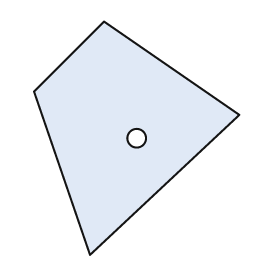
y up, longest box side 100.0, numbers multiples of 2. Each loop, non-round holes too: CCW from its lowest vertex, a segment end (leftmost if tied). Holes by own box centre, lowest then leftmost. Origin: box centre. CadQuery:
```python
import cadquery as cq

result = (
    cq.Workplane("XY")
    .moveTo(-20.0, -50.0)
    .lineTo(44.0, 10.0)
    .lineTo(-14.0, 50.0)
    .lineTo(-44.0, 20.0)
    .close()
    .moveTo(0.0, 0.0)
    .circle(4.0)
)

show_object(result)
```